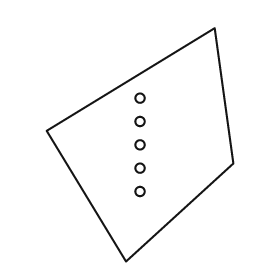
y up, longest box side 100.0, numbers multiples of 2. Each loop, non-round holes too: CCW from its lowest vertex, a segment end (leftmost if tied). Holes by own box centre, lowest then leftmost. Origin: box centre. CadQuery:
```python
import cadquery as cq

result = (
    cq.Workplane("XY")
    .moveTo(-6.0, -50.0)
    .lineTo(40.0, -8.0)
    .lineTo(32.0, 50.0)
    .lineTo(-40.0, 6.0)
    .close()
    .moveTo(0.0, -20.0)
    .circle(2.0)
    .moveTo(0.0, -10.0)
    .circle(2.0)
    .moveTo(0.0, 0.0)
    .circle(2.0)
    .moveTo(0.0, 10.0)
    .circle(2.0)
    .moveTo(0.0, 20.0)
    .circle(2.0)
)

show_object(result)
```